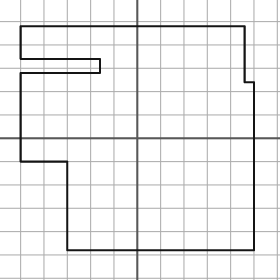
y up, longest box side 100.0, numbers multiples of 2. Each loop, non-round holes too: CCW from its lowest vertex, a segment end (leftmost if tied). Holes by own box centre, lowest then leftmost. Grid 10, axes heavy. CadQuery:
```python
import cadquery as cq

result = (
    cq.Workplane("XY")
    .moveTo(-30.0, -48.0)
    .lineTo(50.0, -48.0)
    .lineTo(50.0, 24.0)
    .lineTo(46.0, 24.0)
    .lineTo(46.0, 48.0)
    .lineTo(-50.0, 48.0)
    .lineTo(-50.0, 34.0)
    .lineTo(-16.0, 34.0)
    .lineTo(-16.0, 28.0)
    .lineTo(-50.0, 28.0)
    .lineTo(-50.0, -10.0)
    .lineTo(-30.0, -10.0)
    .close()
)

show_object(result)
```